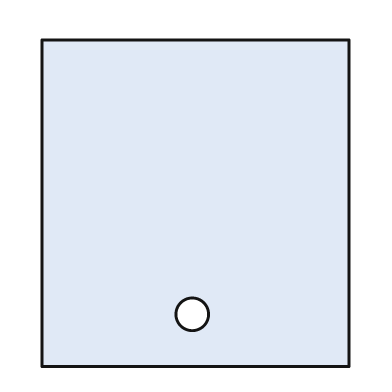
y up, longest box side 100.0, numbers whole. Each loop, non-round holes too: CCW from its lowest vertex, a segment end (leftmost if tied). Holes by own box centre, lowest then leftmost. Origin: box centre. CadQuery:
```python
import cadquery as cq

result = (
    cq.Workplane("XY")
    .moveTo(-47.0, -50.0)
    .lineTo(47.0, -50.0)
    .lineTo(47.0, 50.0)
    .lineTo(-47.0, 50.0)
    .close()
    .moveTo(-1.0, -34.0)
    .circle(5.0)
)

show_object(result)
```